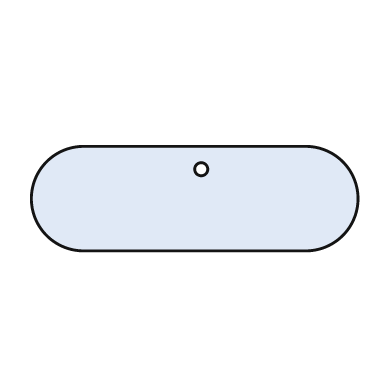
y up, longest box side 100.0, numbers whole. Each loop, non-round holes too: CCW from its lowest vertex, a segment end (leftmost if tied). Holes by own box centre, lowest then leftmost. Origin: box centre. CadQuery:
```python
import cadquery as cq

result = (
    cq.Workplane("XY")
    .moveTo(-34.0, -16.0)
    .lineTo(34.0, -16.0)
    .threePointArc((50.0, 0.0), (34.0, 16.0))
    .lineTo(-34.0, 16.0)
    .threePointArc((-50.0, 0.0), (-34.0, -16.0))
    .close()
    .moveTo(2.0, 9.0)
    .circle(2.0)
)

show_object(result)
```